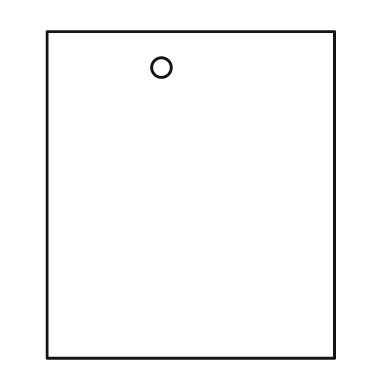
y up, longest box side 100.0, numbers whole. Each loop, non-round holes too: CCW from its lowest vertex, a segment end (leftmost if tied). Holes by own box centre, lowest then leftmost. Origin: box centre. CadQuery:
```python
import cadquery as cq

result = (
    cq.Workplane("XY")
    .moveTo(-44.0, -50.0)
    .lineTo(44.0, -50.0)
    .lineTo(44.0, 50.0)
    .lineTo(-44.0, 50.0)
    .close()
    .moveTo(-9.0, 39.0)
    .circle(3.0)
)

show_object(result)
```